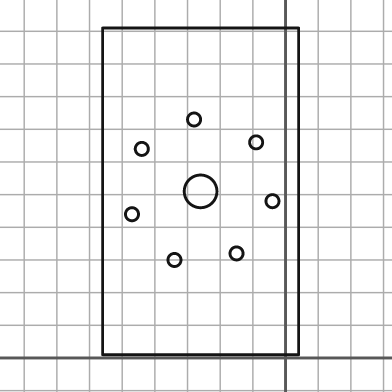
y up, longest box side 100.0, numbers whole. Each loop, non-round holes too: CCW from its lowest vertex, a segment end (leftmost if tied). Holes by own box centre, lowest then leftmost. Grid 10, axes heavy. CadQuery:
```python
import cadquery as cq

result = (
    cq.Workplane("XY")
    .moveTo(-56.0, 1.0)
    .lineTo(4.0, 1.0)
    .lineTo(4.0, 101.0)
    .lineTo(-56.0, 101.0)
    .close()
    .moveTo(-34.0, 30.0)
    .circle(2.0)
    .moveTo(-15.0, 32.0)
    .circle(2.0)
    .moveTo(-47.0, 44.0)
    .circle(2.0)
    .moveTo(-4.0, 48.0)
    .circle(2.0)
    .moveTo(-26.0, 51.0)
    .circle(5.0)
    .moveTo(-44.0, 64.0)
    .circle(2.0)
    .moveTo(-9.0, 66.0)
    .circle(2.0)
    .moveTo(-28.0, 73.0)
    .circle(2.0)
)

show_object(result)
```